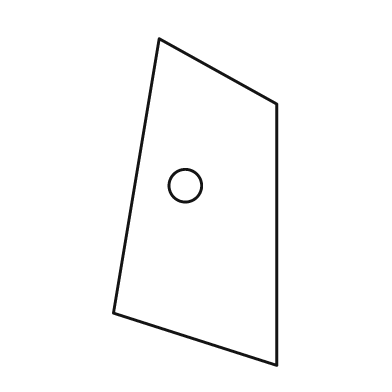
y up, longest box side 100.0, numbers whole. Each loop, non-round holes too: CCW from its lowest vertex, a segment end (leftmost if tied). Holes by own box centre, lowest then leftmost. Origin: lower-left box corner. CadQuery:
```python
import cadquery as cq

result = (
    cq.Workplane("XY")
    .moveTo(50.0, 0.0)
    .lineTo(50.0, 80.0)
    .lineTo(14.0, 100.0)
    .lineTo(0.0, 16.0)
    .close()
    .moveTo(22.0, 55.0)
    .circle(5.0)
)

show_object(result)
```